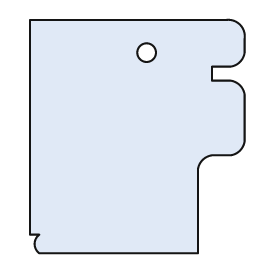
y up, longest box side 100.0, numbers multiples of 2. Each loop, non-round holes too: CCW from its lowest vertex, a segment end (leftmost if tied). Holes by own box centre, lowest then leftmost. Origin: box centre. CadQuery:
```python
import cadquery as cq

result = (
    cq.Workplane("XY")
    .moveTo(-42.0, -50.0)
    .lineTo(26.0, -50.0)
    .lineTo(26.0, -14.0)
    .threePointArc((28.0, -10.0), (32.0, -8.0))
    .lineTo(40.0, -8.0)
    .threePointArc((44.0, -6.0), (46.0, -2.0))
    .lineTo(46.0, 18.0)
    .threePointArc((44.0, 22.0), (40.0, 24.0))
    .lineTo(32.0, 24.0)
    .lineTo(32.0, 30.0)
    .lineTo(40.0, 30.0)
    .threePointArc((44.0, 32.0), (46.0, 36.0))
    .lineTo(46.0, 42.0)
    .threePointArc((44.0, 48.0), (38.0, 50.0))
    .lineTo(-46.0, 50.0)
    .lineTo(-46.0, -42.0)
    .lineTo(-42.0, -42.0)
    .threePointArc((-44.0, -46.0), (-42.0, -50.0))
    .close()
    .moveTo(4.0, 36.0)
    .circle(4.0)
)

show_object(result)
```